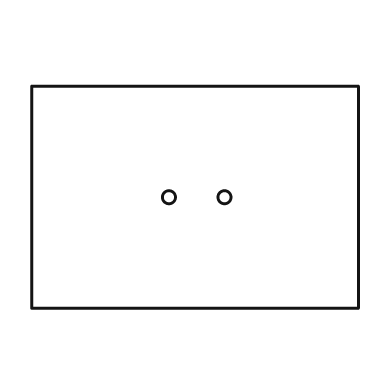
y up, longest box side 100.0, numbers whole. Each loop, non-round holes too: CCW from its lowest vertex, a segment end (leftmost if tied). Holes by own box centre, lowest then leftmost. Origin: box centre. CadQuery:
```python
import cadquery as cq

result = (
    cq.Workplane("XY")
    .moveTo(-50.0, -34.0)
    .lineTo(50.0, -34.0)
    .lineTo(50.0, 34.0)
    .lineTo(-50.0, 34.0)
    .close()
    .moveTo(-8.0, 0.0)
    .circle(2.0)
    .moveTo(9.0, 0.0)
    .circle(2.0)
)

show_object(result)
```